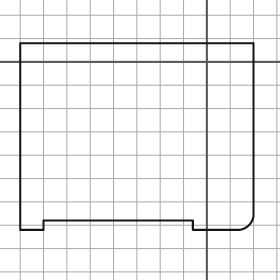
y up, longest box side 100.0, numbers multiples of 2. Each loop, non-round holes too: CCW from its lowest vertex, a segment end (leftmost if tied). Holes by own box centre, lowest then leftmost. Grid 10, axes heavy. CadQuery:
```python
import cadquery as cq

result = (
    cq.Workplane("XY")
    .moveTo(-80.0, -72.0)
    .lineTo(-70.0, -72.0)
    .lineTo(-70.0, -68.0)
    .lineTo(-6.0, -68.0)
    .lineTo(-6.0, -72.0)
    .lineTo(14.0, -72.0)
    .threePointArc((18.0, -70.0), (20.0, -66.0))
    .lineTo(20.0, 8.0)
    .lineTo(-80.0, 8.0)
    .close()
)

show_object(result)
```